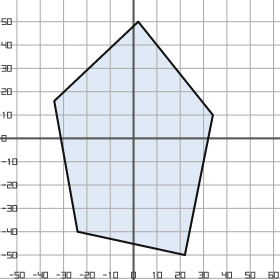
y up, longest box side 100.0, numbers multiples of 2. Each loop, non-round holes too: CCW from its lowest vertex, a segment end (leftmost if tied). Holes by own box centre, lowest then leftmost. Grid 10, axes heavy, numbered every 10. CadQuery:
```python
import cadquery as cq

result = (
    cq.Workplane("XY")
    .moveTo(22.0, -50.0)
    .lineTo(34.0, 10.0)
    .lineTo(2.0, 50.0)
    .lineTo(-34.0, 16.0)
    .lineTo(-24.0, -40.0)
    .close()
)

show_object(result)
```